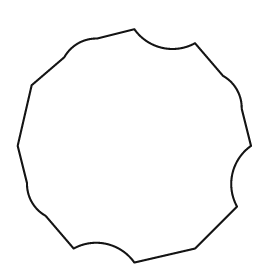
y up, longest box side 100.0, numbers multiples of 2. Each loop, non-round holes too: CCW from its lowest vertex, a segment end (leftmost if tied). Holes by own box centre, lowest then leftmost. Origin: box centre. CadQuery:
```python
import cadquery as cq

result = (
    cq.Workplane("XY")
    .moveTo(0.0, -50.0)
    .lineTo(26.0, -44.0)
    .lineTo(44.0, -26.0)
    .threePointArc((42.0, -12.0), (50.0, 0.0))
    .lineTo(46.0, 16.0)
    .threePointArc((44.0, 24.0), (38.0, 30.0))
    .lineTo(26.0, 44.0)
    .threePointArc((12.0, 42.0), (0.0, 50.0))
    .lineTo(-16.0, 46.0)
    .threePointArc((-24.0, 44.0), (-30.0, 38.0))
    .lineTo(-44.0, 26.0)
    .lineTo(-50.0, 0.0)
    .lineTo(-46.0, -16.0)
    .threePointArc((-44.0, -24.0), (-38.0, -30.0))
    .lineTo(-26.0, -44.0)
    .threePointArc((-12.0, -42.0), (0.0, -50.0))
    .close()
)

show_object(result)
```